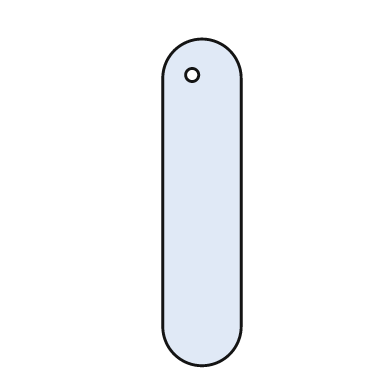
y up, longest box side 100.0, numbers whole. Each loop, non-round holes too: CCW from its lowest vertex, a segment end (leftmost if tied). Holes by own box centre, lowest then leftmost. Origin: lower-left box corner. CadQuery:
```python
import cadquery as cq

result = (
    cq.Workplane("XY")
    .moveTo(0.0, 12.0)
    .threePointArc((12.0, 0.0), (24.0, 12.0))
    .lineTo(24.0, 88.0)
    .threePointArc((12.0, 100.0), (0.0, 88.0))
    .close()
    .moveTo(9.0, 89.0)
    .circle(2.0)
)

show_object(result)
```